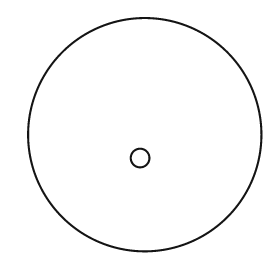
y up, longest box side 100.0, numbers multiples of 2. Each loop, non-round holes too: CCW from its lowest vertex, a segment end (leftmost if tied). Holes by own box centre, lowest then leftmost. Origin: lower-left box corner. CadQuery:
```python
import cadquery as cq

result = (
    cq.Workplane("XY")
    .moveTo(50.0, 50.0)
    .circle(50.0)
    .moveTo(48.0, 40.0)
    .circle(4.0)
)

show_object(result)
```